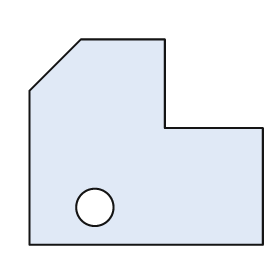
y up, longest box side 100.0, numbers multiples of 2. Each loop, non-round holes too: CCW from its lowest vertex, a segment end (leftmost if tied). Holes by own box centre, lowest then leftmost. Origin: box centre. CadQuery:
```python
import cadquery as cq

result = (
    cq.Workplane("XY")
    .moveTo(-50.0, -44.0)
    .lineTo(50.0, -44.0)
    .lineTo(50.0, 6.0)
    .lineTo(8.0, 6.0)
    .lineTo(8.0, 44.0)
    .lineTo(-28.0, 44.0)
    .lineTo(-50.0, 22.0)
    .close()
    .moveTo(-22.0, -28.0)
    .circle(8.0)
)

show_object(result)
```